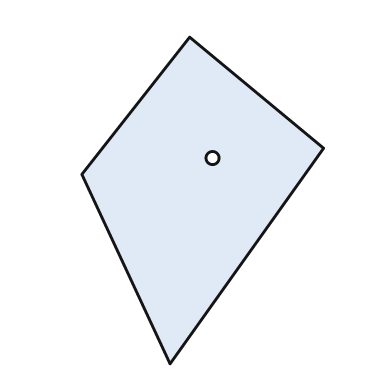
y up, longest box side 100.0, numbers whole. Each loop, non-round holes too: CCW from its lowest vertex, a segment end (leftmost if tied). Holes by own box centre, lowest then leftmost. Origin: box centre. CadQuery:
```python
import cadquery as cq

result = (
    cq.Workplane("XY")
    .moveTo(-10.0, -50.0)
    .lineTo(37.0, 16.0)
    .lineTo(-4.0, 50.0)
    .lineTo(-37.0, 8.0)
    .close()
    .moveTo(3.0, 13.0)
    .circle(2.0)
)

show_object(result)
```